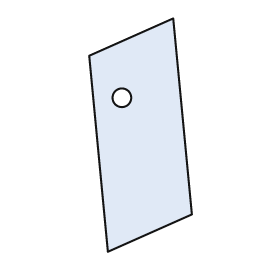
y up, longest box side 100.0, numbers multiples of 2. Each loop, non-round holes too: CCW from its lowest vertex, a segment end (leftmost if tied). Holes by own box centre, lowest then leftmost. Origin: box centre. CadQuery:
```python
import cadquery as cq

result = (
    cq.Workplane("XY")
    .moveTo(-14.0, -50.0)
    .lineTo(22.0, -34.0)
    .lineTo(14.0, 50.0)
    .lineTo(-22.0, 34.0)
    .close()
    .moveTo(-8.0, 16.0)
    .circle(4.0)
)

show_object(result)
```